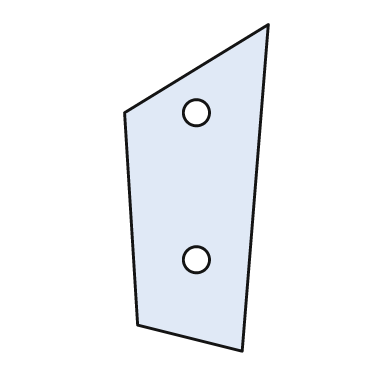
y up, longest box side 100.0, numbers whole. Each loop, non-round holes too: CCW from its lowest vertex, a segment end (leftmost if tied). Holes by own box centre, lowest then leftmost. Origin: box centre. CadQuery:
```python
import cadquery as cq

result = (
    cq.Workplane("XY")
    .moveTo(14.0, -50.0)
    .lineTo(22.0, 50.0)
    .lineTo(-22.0, 23.0)
    .lineTo(-18.0, -42.0)
    .close()
    .moveTo(0.0, -22.0)
    .circle(4.0)
    .moveTo(0.0, 23.0)
    .circle(4.0)
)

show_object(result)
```